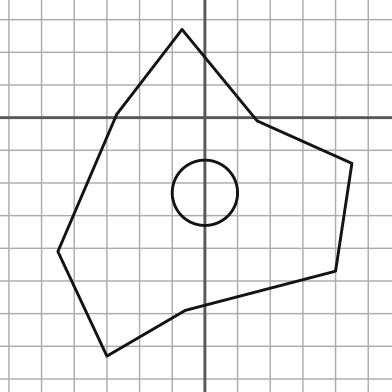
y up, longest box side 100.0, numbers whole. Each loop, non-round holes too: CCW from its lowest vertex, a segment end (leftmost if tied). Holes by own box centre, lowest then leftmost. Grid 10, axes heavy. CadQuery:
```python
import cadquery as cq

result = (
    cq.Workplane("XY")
    .moveTo(-30.0, -73.0)
    .lineTo(-6.0, -59.0)
    .lineTo(40.0, -47.0)
    .lineTo(45.0, -14.0)
    .lineTo(16.0, -1.0)
    .lineTo(-7.0, 27.0)
    .lineTo(-27.0, 1.0)
    .lineTo(-45.0, -41.0)
    .close()
    .moveTo(0.0, -23.0)
    .circle(10.0)
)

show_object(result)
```